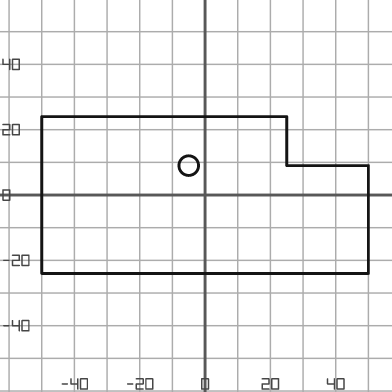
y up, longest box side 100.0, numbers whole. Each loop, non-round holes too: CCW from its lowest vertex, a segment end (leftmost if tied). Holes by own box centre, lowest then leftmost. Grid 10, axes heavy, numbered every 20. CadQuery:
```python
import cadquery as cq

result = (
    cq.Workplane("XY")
    .moveTo(-50.0, -24.0)
    .lineTo(50.0, -24.0)
    .lineTo(50.0, 9.0)
    .lineTo(25.0, 9.0)
    .lineTo(25.0, 24.0)
    .lineTo(-50.0, 24.0)
    .close()
    .moveTo(-5.0, 9.0)
    .circle(3.0)
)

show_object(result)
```